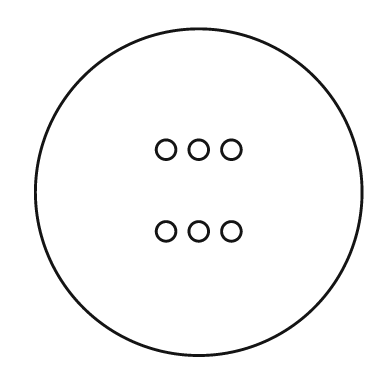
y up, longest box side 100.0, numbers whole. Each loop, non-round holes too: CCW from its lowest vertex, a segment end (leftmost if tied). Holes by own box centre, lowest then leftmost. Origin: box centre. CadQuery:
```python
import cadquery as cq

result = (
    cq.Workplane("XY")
    .moveTo(0.0, 0.0)
    .circle(50.0)
    .moveTo(-10.0, -12.0)
    .circle(3.0)
    .moveTo(0.0, -12.0)
    .circle(3.0)
    .moveTo(10.0, -12.0)
    .circle(3.0)
    .moveTo(-10.0, 13.0)
    .circle(3.0)
    .moveTo(0.0, 13.0)
    .circle(3.0)
    .moveTo(10.0, 13.0)
    .circle(3.0)
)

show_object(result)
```